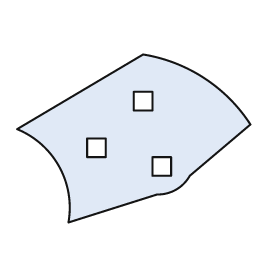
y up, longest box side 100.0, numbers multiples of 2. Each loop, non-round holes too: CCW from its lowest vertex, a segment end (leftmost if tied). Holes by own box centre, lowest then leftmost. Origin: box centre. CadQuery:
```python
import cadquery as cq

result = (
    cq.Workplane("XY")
    .moveTo(-28.0, -36.0)
    .lineTo(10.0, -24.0)
    .threePointArc((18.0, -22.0), (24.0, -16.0))
    .lineTo(50.0, 6.0)
    .threePointArc((30.0, 26.0), (4.0, 36.0))
    .lineTo(-50.0, 4.0)
    .threePointArc((-32.0, -12.0), (-28.0, -36.0))
    .close()
    .moveTo(8.0, -16.0)
    .lineTo(16.0, -16.0)
    .lineTo(16.0, -8.0)
    .lineTo(8.0, -8.0)
    .close()
    .moveTo(-20.0, -8.0)
    .lineTo(-12.0, -8.0)
    .lineTo(-12.0, 0.0)
    .lineTo(-20.0, 0.0)
    .close()
    .moveTo(0.0, 12.0)
    .lineTo(8.0, 12.0)
    .lineTo(8.0, 20.0)
    .lineTo(0.0, 20.0)
    .close()
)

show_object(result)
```